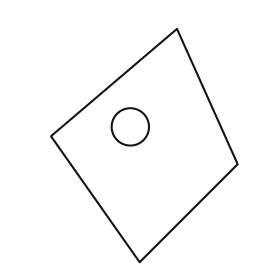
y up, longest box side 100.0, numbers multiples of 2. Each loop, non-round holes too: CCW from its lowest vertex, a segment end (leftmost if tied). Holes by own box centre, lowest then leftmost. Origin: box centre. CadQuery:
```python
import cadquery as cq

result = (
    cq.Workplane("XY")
    .moveTo(-2.0, -50.0)
    .lineTo(40.0, -8.0)
    .lineTo(14.0, 50.0)
    .lineTo(-40.0, 4.0)
    .close()
    .moveTo(-6.0, 8.0)
    .circle(8.0)
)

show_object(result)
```